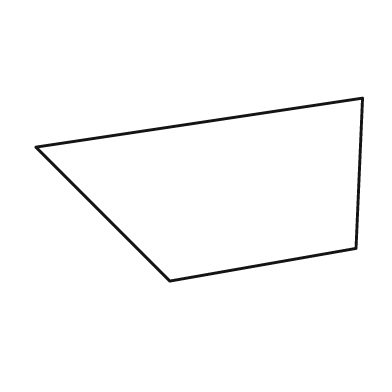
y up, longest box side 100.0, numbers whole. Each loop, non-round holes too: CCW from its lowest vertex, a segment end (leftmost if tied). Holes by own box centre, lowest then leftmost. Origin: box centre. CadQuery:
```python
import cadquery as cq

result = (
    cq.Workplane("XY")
    .moveTo(-9.0, -28.0)
    .lineTo(48.0, -18.0)
    .lineTo(50.0, 28.0)
    .lineTo(-50.0, 13.0)
    .close()
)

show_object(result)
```